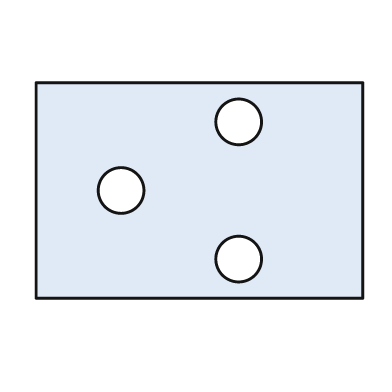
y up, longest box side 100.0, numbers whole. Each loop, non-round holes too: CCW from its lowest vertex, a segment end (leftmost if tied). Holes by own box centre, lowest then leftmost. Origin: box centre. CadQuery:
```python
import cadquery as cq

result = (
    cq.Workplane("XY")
    .moveTo(-50.0, -33.0)
    .lineTo(50.0, -33.0)
    .lineTo(50.0, 33.0)
    .lineTo(-50.0, 33.0)
    .close()
    .moveTo(12.0, -21.0)
    .circle(7.0)
    .moveTo(-24.0, 0.0)
    .circle(7.0)
    .moveTo(12.0, 21.0)
    .circle(7.0)
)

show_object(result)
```